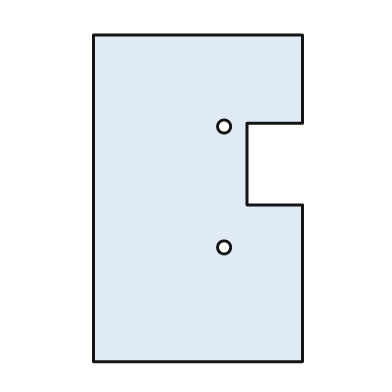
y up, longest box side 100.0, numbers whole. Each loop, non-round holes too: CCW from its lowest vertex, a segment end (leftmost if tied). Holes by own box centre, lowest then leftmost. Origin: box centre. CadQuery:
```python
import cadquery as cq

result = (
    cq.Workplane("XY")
    .moveTo(-32.0, -50.0)
    .lineTo(32.0, -50.0)
    .lineTo(32.0, -2.0)
    .lineTo(15.0, -2.0)
    .lineTo(15.0, 23.0)
    .lineTo(32.0, 23.0)
    .lineTo(32.0, 50.0)
    .lineTo(-32.0, 50.0)
    .close()
    .moveTo(8.0, -15.0)
    .circle(2.0)
    .moveTo(8.0, 22.0)
    .circle(2.0)
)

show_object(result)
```